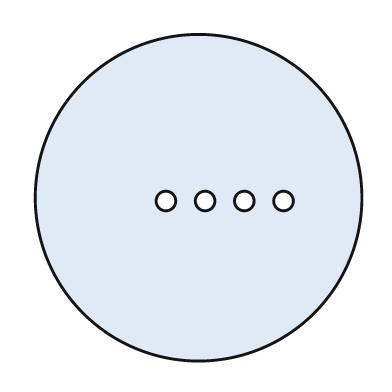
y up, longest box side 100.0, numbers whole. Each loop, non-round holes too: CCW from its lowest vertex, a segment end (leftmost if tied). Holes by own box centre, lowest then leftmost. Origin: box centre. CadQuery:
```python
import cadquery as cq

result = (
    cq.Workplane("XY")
    .moveTo(0.0, 0.0)
    .circle(50.0)
    .moveTo(-10.0, -1.0)
    .circle(3.0)
    .moveTo(2.0, -1.0)
    .circle(3.0)
    .moveTo(14.0, -1.0)
    .circle(3.0)
    .moveTo(26.0, -1.0)
    .circle(3.0)
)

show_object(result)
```